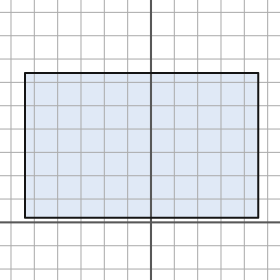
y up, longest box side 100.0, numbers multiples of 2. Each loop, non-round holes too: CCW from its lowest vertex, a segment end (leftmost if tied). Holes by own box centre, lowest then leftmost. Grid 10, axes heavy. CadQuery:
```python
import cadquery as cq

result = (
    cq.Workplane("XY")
    .moveTo(-54.0, 2.0)
    .lineTo(46.0, 2.0)
    .lineTo(46.0, 64.0)
    .lineTo(-54.0, 64.0)
    .close()
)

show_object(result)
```